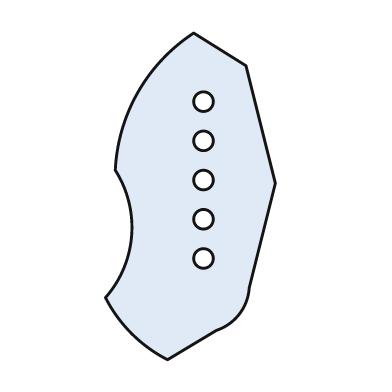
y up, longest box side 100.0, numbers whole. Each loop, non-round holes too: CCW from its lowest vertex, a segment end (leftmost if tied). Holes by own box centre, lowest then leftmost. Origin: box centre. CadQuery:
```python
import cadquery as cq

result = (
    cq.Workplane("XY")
    .moveTo(-7.0, -50.0)
    .lineTo(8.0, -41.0)
    .threePointArc((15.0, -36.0), (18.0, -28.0))
    .lineTo(26.0, 4.0)
    .lineTo(17.0, 40.0)
    .lineTo(1.0, 50.0)
    .threePointArc((-16.0, 32.0), (-23.0, 8.0))
    .threePointArc((-18.0, -12.0), (-26.0, -31.0))
    .threePointArc((-18.0, -42.0), (-7.0, -50.0))
    .close()
    .moveTo(4.0, -19.0)
    .circle(3.0)
    .moveTo(4.0, -7.0)
    .circle(3.0)
    .moveTo(4.0, 5.0)
    .circle(3.0)
    .moveTo(4.0, 17.0)
    .circle(3.0)
    .moveTo(4.0, 29.0)
    .circle(3.0)
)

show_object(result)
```